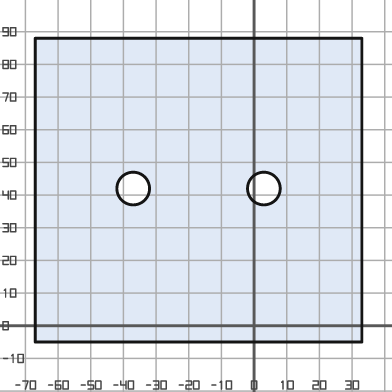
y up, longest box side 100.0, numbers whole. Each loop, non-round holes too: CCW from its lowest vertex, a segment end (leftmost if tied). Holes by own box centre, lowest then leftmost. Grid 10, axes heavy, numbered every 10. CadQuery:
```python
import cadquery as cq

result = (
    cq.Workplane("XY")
    .moveTo(-67.0, -5.0)
    .lineTo(33.0, -5.0)
    .lineTo(33.0, 88.0)
    .lineTo(-67.0, 88.0)
    .close()
    .moveTo(-37.0, 42.0)
    .circle(5.0)
    .moveTo(3.0, 42.0)
    .circle(5.0)
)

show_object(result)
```